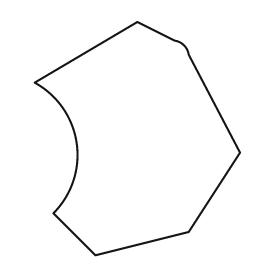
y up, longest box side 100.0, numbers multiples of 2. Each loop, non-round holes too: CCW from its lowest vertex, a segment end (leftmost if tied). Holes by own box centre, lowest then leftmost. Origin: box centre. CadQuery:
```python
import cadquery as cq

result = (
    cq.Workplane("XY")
    .moveTo(-18.0, -50.0)
    .lineTo(22.0, -40.0)
    .lineTo(44.0, -6.0)
    .lineTo(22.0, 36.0)
    .threePointArc((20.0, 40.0), (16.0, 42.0))
    .lineTo(0.0, 50.0)
    .lineTo(-44.0, 24.0)
    .threePointArc((-26.0, -2.0), (-36.0, -32.0))
    .close()
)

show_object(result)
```